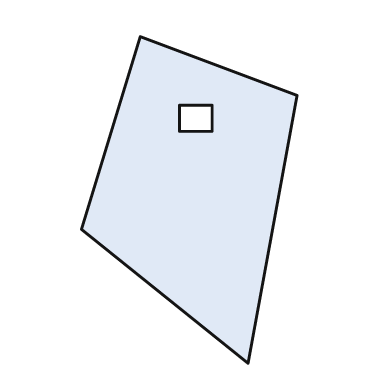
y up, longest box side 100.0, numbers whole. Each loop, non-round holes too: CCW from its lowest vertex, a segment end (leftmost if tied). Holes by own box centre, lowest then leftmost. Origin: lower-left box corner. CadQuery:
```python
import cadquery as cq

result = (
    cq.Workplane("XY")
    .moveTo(51.0, 0.0)
    .lineTo(66.0, 82.0)
    .lineTo(18.0, 100.0)
    .lineTo(0.0, 41.0)
    .close()
    .moveTo(30.0, 71.0)
    .lineTo(40.0, 71.0)
    .lineTo(40.0, 79.0)
    .lineTo(30.0, 79.0)
    .close()
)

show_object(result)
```